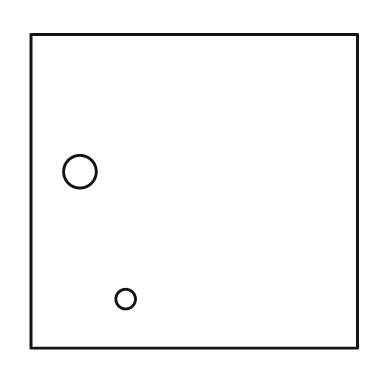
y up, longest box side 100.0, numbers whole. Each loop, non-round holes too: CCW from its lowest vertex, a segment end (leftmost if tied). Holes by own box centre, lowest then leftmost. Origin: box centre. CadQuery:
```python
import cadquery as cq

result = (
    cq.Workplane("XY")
    .moveTo(-50.0, -48.0)
    .lineTo(50.0, -48.0)
    .lineTo(50.0, 48.0)
    .lineTo(-50.0, 48.0)
    .close()
    .moveTo(-21.0, -33.0)
    .circle(3.0)
    .moveTo(-35.0, 6.0)
    .circle(5.0)
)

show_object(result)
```